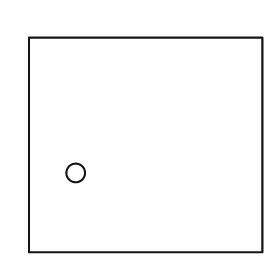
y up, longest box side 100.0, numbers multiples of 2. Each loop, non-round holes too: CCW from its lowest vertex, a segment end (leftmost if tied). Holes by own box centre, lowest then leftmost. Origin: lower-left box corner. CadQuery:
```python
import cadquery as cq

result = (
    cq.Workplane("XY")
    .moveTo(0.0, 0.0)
    .lineTo(100.0, 0.0)
    .lineTo(100.0, 92.0)
    .lineTo(0.0, 92.0)
    .close()
    .moveTo(20.0, 34.0)
    .circle(4.0)
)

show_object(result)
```